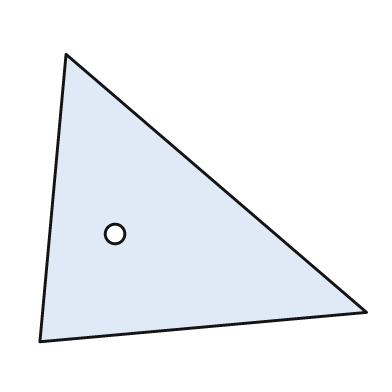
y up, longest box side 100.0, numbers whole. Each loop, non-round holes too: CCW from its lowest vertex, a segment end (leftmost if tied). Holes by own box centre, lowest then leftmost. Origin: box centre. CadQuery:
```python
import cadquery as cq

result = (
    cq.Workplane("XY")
    .moveTo(-50.0, -44.0)
    .lineTo(50.0, -35.0)
    .lineTo(-42.0, 44.0)
    .close()
    .moveTo(-27.0, -11.0)
    .circle(3.0)
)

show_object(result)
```